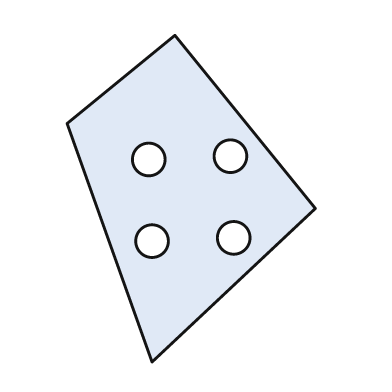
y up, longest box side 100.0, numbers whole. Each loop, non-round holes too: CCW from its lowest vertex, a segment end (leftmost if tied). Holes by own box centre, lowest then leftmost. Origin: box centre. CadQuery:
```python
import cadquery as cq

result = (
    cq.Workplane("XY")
    .moveTo(-12.0, -50.0)
    .lineTo(38.0, -3.0)
    .lineTo(-5.0, 50.0)
    .lineTo(-38.0, 23.0)
    .close()
    .moveTo(-12.0, -13.0)
    .circle(5.0)
    .moveTo(13.0, -12.0)
    .circle(5.0)
    .moveTo(-13.0, 12.0)
    .circle(5.0)
    .moveTo(12.0, 13.0)
    .circle(5.0)
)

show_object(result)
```